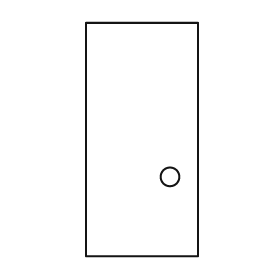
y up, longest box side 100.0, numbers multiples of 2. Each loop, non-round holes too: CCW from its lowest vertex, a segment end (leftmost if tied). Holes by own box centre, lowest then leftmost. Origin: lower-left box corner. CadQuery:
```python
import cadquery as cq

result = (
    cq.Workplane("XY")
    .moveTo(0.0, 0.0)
    .lineTo(48.0, 0.0)
    .lineTo(48.0, 100.0)
    .lineTo(0.0, 100.0)
    .close()
    .moveTo(36.0, 34.0)
    .circle(4.0)
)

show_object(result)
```